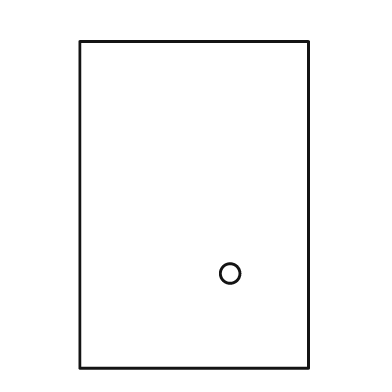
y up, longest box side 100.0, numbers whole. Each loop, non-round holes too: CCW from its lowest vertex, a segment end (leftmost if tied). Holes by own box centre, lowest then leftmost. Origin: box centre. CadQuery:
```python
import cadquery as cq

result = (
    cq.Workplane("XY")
    .moveTo(-35.0, -50.0)
    .lineTo(35.0, -50.0)
    .lineTo(35.0, 50.0)
    .lineTo(-35.0, 50.0)
    .close()
    .moveTo(11.0, -21.0)
    .circle(3.0)
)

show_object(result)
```